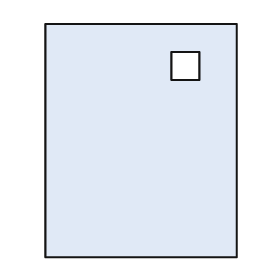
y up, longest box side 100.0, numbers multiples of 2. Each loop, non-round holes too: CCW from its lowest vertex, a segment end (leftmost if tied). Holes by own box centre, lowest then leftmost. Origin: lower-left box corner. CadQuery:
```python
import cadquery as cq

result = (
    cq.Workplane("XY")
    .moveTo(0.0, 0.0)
    .lineTo(82.0, 0.0)
    .lineTo(82.0, 100.0)
    .lineTo(0.0, 100.0)
    .close()
    .moveTo(54.0, 76.0)
    .lineTo(66.0, 76.0)
    .lineTo(66.0, 88.0)
    .lineTo(54.0, 88.0)
    .close()
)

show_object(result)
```